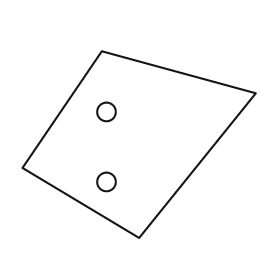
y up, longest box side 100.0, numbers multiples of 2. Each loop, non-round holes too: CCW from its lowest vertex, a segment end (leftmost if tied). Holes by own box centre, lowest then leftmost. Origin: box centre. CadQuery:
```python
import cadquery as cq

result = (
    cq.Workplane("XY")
    .moveTo(0.0, -40.0)
    .lineTo(50.0, 22.0)
    .lineTo(-16.0, 40.0)
    .lineTo(-50.0, -10.0)
    .close()
    .moveTo(-14.0, -16.0)
    .circle(4.0)
    .moveTo(-14.0, 14.0)
    .circle(4.0)
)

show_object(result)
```